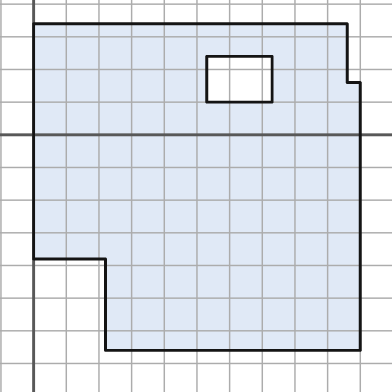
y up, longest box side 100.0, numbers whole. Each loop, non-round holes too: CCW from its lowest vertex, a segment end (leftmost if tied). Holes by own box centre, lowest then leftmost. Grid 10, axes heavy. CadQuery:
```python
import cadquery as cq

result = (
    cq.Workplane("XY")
    .moveTo(22.0, -66.0)
    .lineTo(100.0, -66.0)
    .lineTo(100.0, 16.0)
    .lineTo(96.0, 16.0)
    .lineTo(96.0, 34.0)
    .lineTo(0.0, 34.0)
    .lineTo(0.0, -38.0)
    .lineTo(22.0, -38.0)
    .close()
    .moveTo(53.0, 10.0)
    .lineTo(73.0, 10.0)
    .lineTo(73.0, 24.0)
    .lineTo(53.0, 24.0)
    .close()
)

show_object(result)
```